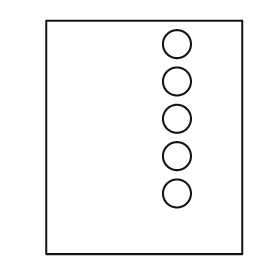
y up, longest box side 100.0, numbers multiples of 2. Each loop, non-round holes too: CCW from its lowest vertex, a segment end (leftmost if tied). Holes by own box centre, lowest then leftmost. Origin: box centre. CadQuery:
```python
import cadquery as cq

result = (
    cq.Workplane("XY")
    .moveTo(-42.0, -50.0)
    .lineTo(42.0, -50.0)
    .lineTo(42.0, 50.0)
    .lineTo(-42.0, 50.0)
    .close()
    .moveTo(14.0, -24.0)
    .circle(6.0)
    .moveTo(14.0, -8.0)
    .circle(6.0)
    .moveTo(14.0, 8.0)
    .circle(6.0)
    .moveTo(14.0, 24.0)
    .circle(6.0)
    .moveTo(14.0, 40.0)
    .circle(6.0)
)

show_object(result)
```